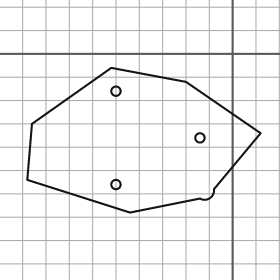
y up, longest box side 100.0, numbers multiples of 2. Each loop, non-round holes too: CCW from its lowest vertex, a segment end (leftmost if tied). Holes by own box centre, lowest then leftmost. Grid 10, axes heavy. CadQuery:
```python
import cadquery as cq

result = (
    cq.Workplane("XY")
    .moveTo(-44.0, -68.0)
    .lineTo(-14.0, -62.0)
    .threePointArc((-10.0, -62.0), (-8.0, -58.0))
    .lineTo(12.0, -34.0)
    .lineTo(-20.0, -12.0)
    .lineTo(-52.0, -6.0)
    .lineTo(-86.0, -30.0)
    .lineTo(-88.0, -54.0)
    .close()
    .moveTo(-50.0, -56.0)
    .circle(2.0)
    .moveTo(-14.0, -36.0)
    .circle(2.0)
    .moveTo(-50.0, -16.0)
    .circle(2.0)
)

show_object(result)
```